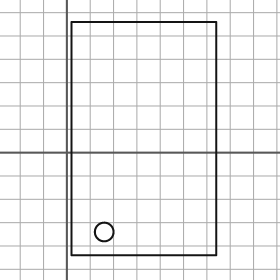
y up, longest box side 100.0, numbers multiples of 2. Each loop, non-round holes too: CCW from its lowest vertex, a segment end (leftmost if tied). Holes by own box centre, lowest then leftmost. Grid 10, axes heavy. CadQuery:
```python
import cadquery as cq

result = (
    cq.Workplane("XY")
    .moveTo(2.0, -44.0)
    .lineTo(64.0, -44.0)
    .lineTo(64.0, 56.0)
    .lineTo(2.0, 56.0)
    .close()
    .moveTo(16.0, -34.0)
    .circle(4.0)
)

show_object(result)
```